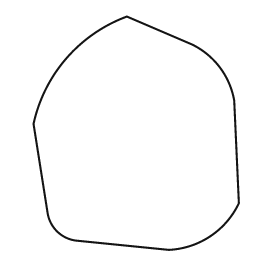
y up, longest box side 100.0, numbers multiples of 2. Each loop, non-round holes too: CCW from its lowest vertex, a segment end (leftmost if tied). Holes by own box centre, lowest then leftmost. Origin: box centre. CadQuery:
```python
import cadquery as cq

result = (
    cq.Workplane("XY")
    .moveTo(14.0, -50.0)
    .threePointArc((32.0, -44.0), (44.0, -30.0))
    .lineTo(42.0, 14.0)
    .threePointArc((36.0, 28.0), (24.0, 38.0))
    .lineTo(-4.0, 50.0)
    .threePointArc((-30.0, 32.0), (-44.0, 4.0))
    .lineTo(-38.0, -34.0)
    .threePointArc((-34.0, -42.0), (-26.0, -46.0))
    .close()
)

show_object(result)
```